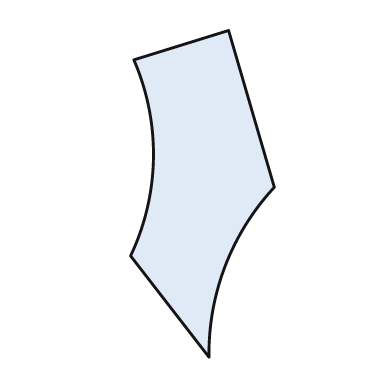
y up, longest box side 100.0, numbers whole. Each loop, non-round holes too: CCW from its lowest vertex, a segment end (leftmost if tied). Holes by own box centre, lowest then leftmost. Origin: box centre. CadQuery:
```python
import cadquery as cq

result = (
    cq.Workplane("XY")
    .moveTo(2.0, -50.0)
    .threePointArc((7.0, -22.0), (22.0, 2.0))
    .lineTo(8.0, 50.0)
    .lineTo(-21.0, 41.0)
    .threePointArc((-15.0, 11.0), (-22.0, -19.0))
    .close()
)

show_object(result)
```